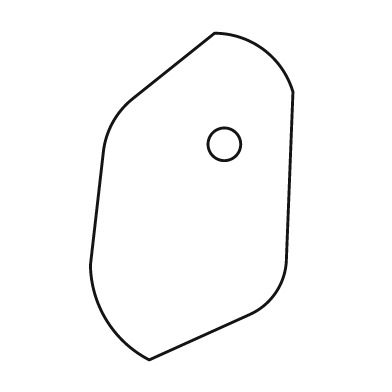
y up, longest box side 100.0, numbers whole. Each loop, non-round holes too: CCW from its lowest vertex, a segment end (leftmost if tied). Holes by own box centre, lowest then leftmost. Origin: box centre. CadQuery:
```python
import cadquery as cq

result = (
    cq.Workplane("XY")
    .moveTo(-13.0, -50.0)
    .lineTo(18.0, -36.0)
    .threePointArc((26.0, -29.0), (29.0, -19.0))
    .lineTo(31.0, 32.0)
    .threePointArc((22.0, 45.0), (7.0, 50.0))
    .lineTo(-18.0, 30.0)
    .threePointArc((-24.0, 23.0), (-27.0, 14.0))
    .lineTo(-31.0, -21.0)
    .threePointArc((-26.0, -38.0), (-13.0, -50.0))
    .close()
    .moveTo(10.0, 16.0)
    .circle(5.0)
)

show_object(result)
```